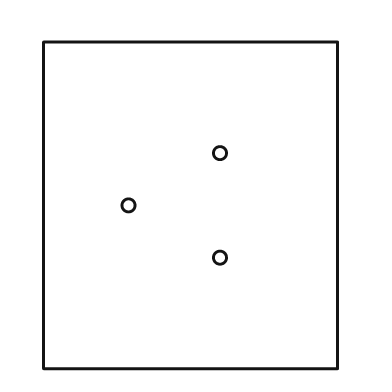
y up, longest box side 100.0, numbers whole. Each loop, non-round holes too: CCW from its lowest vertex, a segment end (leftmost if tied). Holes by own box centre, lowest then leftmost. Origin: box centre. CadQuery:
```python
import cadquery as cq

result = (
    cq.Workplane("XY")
    .moveTo(-45.0, -50.0)
    .lineTo(45.0, -50.0)
    .lineTo(45.0, 50.0)
    .lineTo(-45.0, 50.0)
    .close()
    .moveTo(9.0, -16.0)
    .circle(2.0)
    .moveTo(-19.0, 0.0)
    .circle(2.0)
    .moveTo(9.0, 16.0)
    .circle(2.0)
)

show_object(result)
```